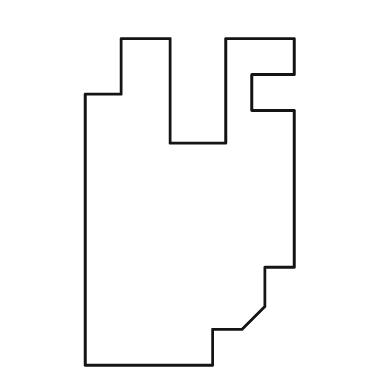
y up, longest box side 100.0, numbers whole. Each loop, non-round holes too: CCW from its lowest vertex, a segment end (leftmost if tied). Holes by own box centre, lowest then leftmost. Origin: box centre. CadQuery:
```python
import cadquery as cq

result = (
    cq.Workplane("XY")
    .moveTo(-32.0, -50.0)
    .lineTo(7.0, -50.0)
    .lineTo(7.0, -39.0)
    .lineTo(16.0, -39.0)
    .lineTo(23.0, -32.0)
    .lineTo(23.0, -20.0)
    .lineTo(32.0, -20.0)
    .lineTo(32.0, 28.0)
    .lineTo(19.0, 28.0)
    .lineTo(19.0, 39.0)
    .lineTo(32.0, 39.0)
    .lineTo(32.0, 50.0)
    .lineTo(11.0, 50.0)
    .lineTo(11.0, 18.0)
    .lineTo(-6.0, 18.0)
    .lineTo(-6.0, 50.0)
    .lineTo(-21.0, 50.0)
    .lineTo(-21.0, 33.0)
    .lineTo(-32.0, 33.0)
    .close()
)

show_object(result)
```